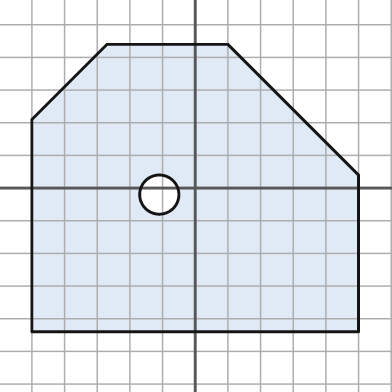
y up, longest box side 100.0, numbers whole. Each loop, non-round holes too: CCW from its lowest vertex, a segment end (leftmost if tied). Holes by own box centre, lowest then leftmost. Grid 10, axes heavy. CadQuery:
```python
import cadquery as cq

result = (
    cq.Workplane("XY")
    .moveTo(-50.0, -44.0)
    .lineTo(50.0, -44.0)
    .lineTo(50.0, 4.0)
    .lineTo(10.0, 44.0)
    .lineTo(-27.0, 44.0)
    .lineTo(-50.0, 21.0)
    .close()
    .moveTo(-11.0, -2.0)
    .circle(6.0)
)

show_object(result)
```